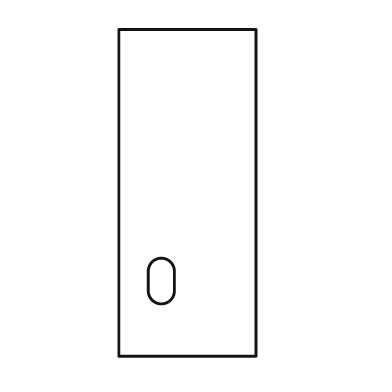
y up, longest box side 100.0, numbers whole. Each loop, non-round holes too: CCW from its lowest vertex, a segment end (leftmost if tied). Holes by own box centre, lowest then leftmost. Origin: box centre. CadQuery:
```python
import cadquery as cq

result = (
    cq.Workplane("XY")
    .moveTo(-21.0, -50.0)
    .lineTo(21.0, -50.0)
    .lineTo(21.0, 50.0)
    .lineTo(-21.0, 50.0)
    .close()
    .moveTo(-12.0, -30.0)
    .threePointArc((-8.0, -34.0), (-4.0, -30.0))
    .lineTo(-4.0, -24.0)
    .threePointArc((-8.0, -20.0), (-12.0, -24.0))
    .close()
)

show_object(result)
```